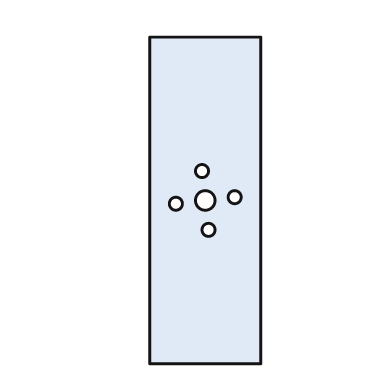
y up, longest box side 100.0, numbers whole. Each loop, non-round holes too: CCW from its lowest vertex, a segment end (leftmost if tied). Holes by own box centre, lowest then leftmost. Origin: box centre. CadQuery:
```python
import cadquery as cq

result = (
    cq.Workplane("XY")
    .moveTo(-17.0, -50.0)
    .lineTo(17.0, -50.0)
    .lineTo(17.0, 50.0)
    .lineTo(-17.0, 50.0)
    .close()
    .moveTo(1.0, -9.0)
    .circle(2.0)
    .moveTo(-9.0, -1.0)
    .circle(2.0)
    .moveTo(0.0, 0.0)
    .circle(3.0)
    .moveTo(9.0, 1.0)
    .circle(2.0)
    .moveTo(-1.0, 9.0)
    .circle(2.0)
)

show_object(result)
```